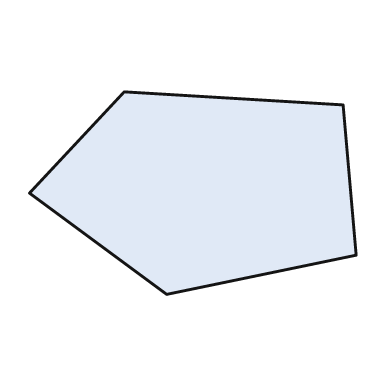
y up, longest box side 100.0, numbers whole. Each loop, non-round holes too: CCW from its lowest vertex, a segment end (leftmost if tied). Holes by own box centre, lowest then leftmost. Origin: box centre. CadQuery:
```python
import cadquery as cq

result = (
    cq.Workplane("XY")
    .moveTo(-8.0, -31.0)
    .lineTo(50.0, -19.0)
    .lineTo(46.0, 27.0)
    .lineTo(-21.0, 31.0)
    .lineTo(-50.0, 0.0)
    .close()
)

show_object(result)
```